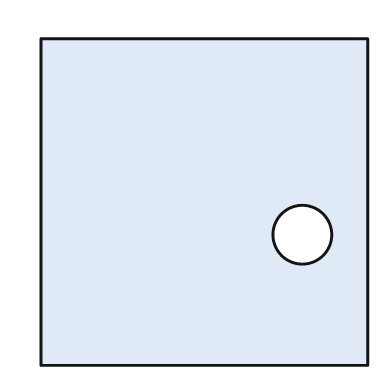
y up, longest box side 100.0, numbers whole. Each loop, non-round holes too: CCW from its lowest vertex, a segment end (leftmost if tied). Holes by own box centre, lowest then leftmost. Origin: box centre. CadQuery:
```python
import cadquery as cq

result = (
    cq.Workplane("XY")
    .moveTo(-50.0, -50.0)
    .lineTo(50.0, -50.0)
    .lineTo(50.0, 50.0)
    .lineTo(-50.0, 50.0)
    .close()
    .moveTo(30.0, -10.0)
    .circle(9.0)
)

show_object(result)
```